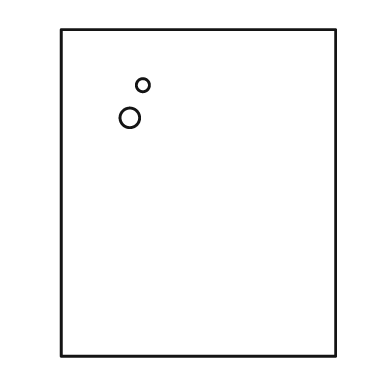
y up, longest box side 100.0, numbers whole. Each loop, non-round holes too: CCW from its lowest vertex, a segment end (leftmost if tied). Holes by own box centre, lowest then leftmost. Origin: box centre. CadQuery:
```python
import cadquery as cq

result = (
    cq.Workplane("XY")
    .moveTo(-42.0, -50.0)
    .lineTo(42.0, -50.0)
    .lineTo(42.0, 50.0)
    .lineTo(-42.0, 50.0)
    .close()
    .moveTo(-21.0, 23.0)
    .circle(3.0)
    .moveTo(-17.0, 33.0)
    .circle(2.0)
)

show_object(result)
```